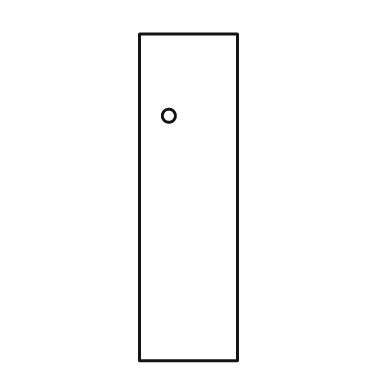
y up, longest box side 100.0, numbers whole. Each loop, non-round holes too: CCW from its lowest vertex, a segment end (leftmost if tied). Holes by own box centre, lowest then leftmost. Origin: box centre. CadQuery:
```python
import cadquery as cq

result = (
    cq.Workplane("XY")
    .moveTo(-15.0, -50.0)
    .lineTo(15.0, -50.0)
    .lineTo(15.0, 50.0)
    .lineTo(-15.0, 50.0)
    .close()
    .moveTo(-6.0, 25.0)
    .circle(2.0)
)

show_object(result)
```